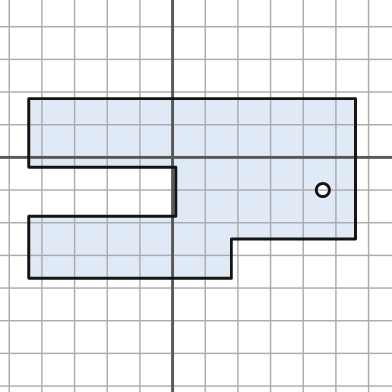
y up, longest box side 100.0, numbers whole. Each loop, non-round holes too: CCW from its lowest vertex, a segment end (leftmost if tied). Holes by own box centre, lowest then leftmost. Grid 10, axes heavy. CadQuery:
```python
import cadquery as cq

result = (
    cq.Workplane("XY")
    .moveTo(-44.0, -37.0)
    .lineTo(18.0, -37.0)
    .lineTo(18.0, -25.0)
    .lineTo(56.0, -25.0)
    .lineTo(56.0, 18.0)
    .lineTo(-44.0, 18.0)
    .lineTo(-44.0, -3.0)
    .lineTo(1.0, -3.0)
    .lineTo(1.0, -18.0)
    .lineTo(-44.0, -18.0)
    .close()
    .moveTo(46.0, -10.0)
    .circle(2.0)
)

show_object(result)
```